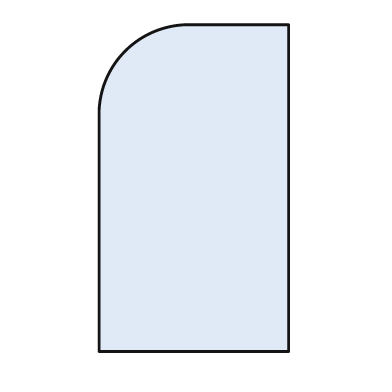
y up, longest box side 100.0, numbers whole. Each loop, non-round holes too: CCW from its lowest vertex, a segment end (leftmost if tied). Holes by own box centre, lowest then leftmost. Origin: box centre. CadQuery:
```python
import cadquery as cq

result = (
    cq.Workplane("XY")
    .moveTo(-29.0, -50.0)
    .lineTo(29.0, -50.0)
    .lineTo(29.0, 50.0)
    .lineTo(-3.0, 50.0)
    .threePointArc((-21.0, 42.0), (-29.0, 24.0))
    .close()
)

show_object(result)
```